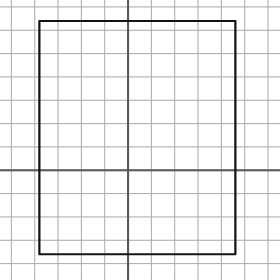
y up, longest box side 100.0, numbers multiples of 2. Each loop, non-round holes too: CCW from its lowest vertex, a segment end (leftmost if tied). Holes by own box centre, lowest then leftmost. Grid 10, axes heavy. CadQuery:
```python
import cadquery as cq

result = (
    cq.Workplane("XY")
    .moveTo(-38.0, -36.0)
    .lineTo(46.0, -36.0)
    .lineTo(46.0, 64.0)
    .lineTo(-38.0, 64.0)
    .close()
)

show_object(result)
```